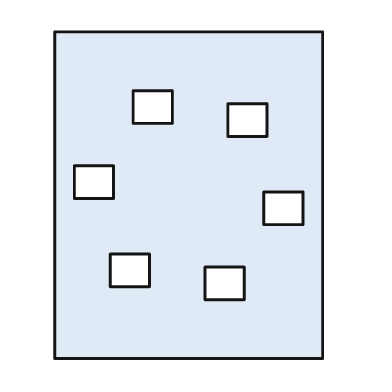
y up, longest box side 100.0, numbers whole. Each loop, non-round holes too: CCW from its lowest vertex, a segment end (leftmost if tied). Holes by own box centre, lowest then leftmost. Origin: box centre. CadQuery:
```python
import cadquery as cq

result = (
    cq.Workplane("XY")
    .moveTo(-41.0, -50.0)
    .lineTo(41.0, -50.0)
    .lineTo(41.0, 50.0)
    .lineTo(-41.0, 50.0)
    .close()
    .moveTo(5.0, -32.0)
    .lineTo(17.0, -32.0)
    .lineTo(17.0, -22.0)
    .lineTo(5.0, -22.0)
    .close()
    .moveTo(-24.0, -28.0)
    .lineTo(-12.0, -28.0)
    .lineTo(-12.0, -18.0)
    .lineTo(-24.0, -18.0)
    .close()
    .moveTo(23.0, -9.0)
    .lineTo(35.0, -9.0)
    .lineTo(35.0, 1.0)
    .lineTo(23.0, 1.0)
    .close()
    .moveTo(-35.0, -1.0)
    .lineTo(-23.0, -1.0)
    .lineTo(-23.0, 9.0)
    .lineTo(-35.0, 9.0)
    .close()
    .moveTo(12.0, 18.0)
    .lineTo(24.0, 18.0)
    .lineTo(24.0, 28.0)
    .lineTo(12.0, 28.0)
    .close()
    .moveTo(-17.0, 22.0)
    .lineTo(-5.0, 22.0)
    .lineTo(-5.0, 32.0)
    .lineTo(-17.0, 32.0)
    .close()
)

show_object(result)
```